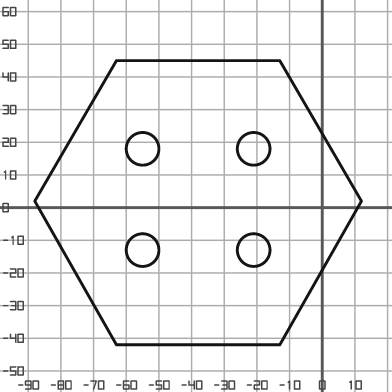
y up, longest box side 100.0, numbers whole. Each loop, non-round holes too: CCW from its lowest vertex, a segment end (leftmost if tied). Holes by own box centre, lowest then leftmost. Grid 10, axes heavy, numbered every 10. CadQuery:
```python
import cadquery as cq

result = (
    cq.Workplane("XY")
    .moveTo(-63.0, -42.0)
    .lineTo(-13.0, -42.0)
    .lineTo(12.0, 2.0)
    .lineTo(-13.0, 45.0)
    .lineTo(-63.0, 45.0)
    .lineTo(-88.0, 2.0)
    .close()
    .moveTo(-55.0, -13.0)
    .circle(5.0)
    .moveTo(-21.0, -13.0)
    .circle(5.0)
    .moveTo(-55.0, 18.0)
    .circle(5.0)
    .moveTo(-21.0, 18.0)
    .circle(5.0)
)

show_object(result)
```